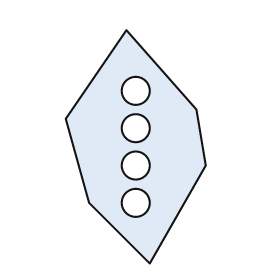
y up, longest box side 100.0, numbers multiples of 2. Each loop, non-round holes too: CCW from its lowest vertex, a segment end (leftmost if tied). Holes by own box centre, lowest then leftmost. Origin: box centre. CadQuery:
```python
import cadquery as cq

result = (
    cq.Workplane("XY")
    .moveTo(6.0, -50.0)
    .lineTo(30.0, -8.0)
    .lineTo(26.0, 16.0)
    .lineTo(-4.0, 50.0)
    .lineTo(-30.0, 12.0)
    .lineTo(-20.0, -24.0)
    .close()
    .moveTo(0.0, -24.0)
    .circle(6.0)
    .moveTo(0.0, -8.0)
    .circle(6.0)
    .moveTo(0.0, 8.0)
    .circle(6.0)
    .moveTo(0.0, 24.0)
    .circle(6.0)
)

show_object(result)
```